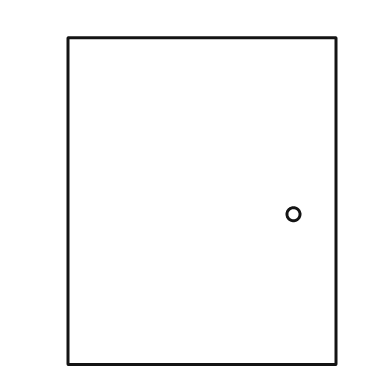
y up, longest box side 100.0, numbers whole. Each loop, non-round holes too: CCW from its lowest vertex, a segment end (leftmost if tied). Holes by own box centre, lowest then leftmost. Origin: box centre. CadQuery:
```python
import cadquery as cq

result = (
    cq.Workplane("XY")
    .moveTo(-41.0, -50.0)
    .lineTo(41.0, -50.0)
    .lineTo(41.0, 50.0)
    .lineTo(-41.0, 50.0)
    .close()
    .moveTo(28.0, -4.0)
    .circle(2.0)
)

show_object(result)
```